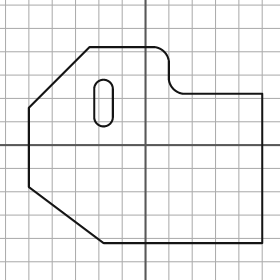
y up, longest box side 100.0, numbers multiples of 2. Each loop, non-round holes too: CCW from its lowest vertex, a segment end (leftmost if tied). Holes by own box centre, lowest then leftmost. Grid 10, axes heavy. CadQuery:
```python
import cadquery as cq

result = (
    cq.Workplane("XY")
    .moveTo(-18.0, -42.0)
    .lineTo(50.0, -42.0)
    .lineTo(50.0, 22.0)
    .lineTo(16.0, 22.0)
    .threePointArc((12.0, 24.0), (10.0, 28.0))
    .lineTo(10.0, 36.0)
    .threePointArc((8.0, 40.0), (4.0, 42.0))
    .lineTo(-24.0, 42.0)
    .lineTo(-50.0, 16.0)
    .lineTo(-50.0, -18.0)
    .close()
    .moveTo(-22.0, 12.0)
    .threePointArc((-18.0, 8.0), (-14.0, 12.0))
    .lineTo(-14.0, 24.0)
    .threePointArc((-18.0, 28.0), (-22.0, 24.0))
    .close()
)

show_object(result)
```